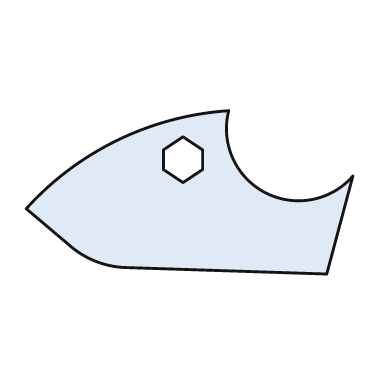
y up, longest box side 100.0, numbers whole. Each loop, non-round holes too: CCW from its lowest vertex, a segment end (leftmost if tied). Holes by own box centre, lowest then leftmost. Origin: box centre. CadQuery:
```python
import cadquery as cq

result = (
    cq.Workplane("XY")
    .moveTo(42.0, -25.0)
    .lineTo(50.0, 5.0)
    .threePointArc((23.0, 0.0), (12.0, 25.0))
    .threePointArc((-22.0, 16.0), (-50.0, -5.0))
    .lineTo(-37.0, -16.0)
    .threePointArc((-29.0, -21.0), (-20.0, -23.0))
    .close()
    .moveTo(-2.0, 3.0)
    .lineTo(4.0, 7.0)
    .lineTo(4.0, 13.0)
    .lineTo(-2.0, 17.0)
    .lineTo(-8.0, 13.0)
    .lineTo(-8.0, 7.0)
    .close()
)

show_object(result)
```